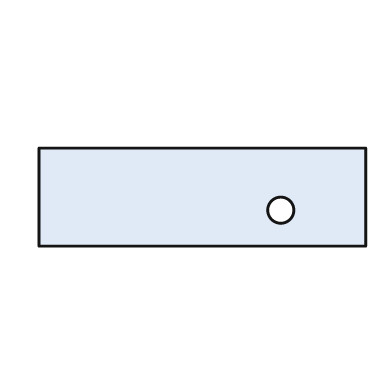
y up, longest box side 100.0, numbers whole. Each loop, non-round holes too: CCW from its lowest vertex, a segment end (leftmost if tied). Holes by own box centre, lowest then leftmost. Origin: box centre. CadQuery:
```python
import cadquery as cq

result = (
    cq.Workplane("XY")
    .moveTo(-50.0, -15.0)
    .lineTo(50.0, -15.0)
    .lineTo(50.0, 15.0)
    .lineTo(-50.0, 15.0)
    .close()
    .moveTo(24.0, -4.0)
    .circle(4.0)
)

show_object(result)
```